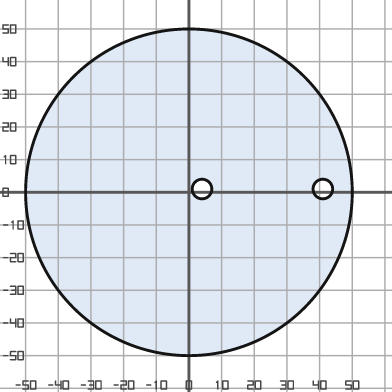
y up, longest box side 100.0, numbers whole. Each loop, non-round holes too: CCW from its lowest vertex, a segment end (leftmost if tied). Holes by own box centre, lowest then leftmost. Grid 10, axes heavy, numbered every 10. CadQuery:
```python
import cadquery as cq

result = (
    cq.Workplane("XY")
    .moveTo(0.0, 0.0)
    .circle(50.0)
    .moveTo(4.0, 1.0)
    .circle(3.0)
    .moveTo(41.0, 1.0)
    .circle(3.0)
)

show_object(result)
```